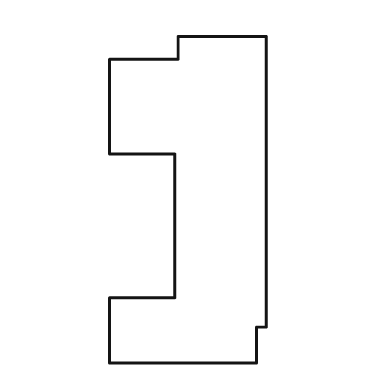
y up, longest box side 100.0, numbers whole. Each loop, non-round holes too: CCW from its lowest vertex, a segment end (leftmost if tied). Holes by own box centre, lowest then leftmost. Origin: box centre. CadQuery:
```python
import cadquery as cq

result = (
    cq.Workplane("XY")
    .moveTo(-24.0, -50.0)
    .lineTo(21.0, -50.0)
    .lineTo(21.0, -39.0)
    .lineTo(24.0, -39.0)
    .lineTo(24.0, 50.0)
    .lineTo(-3.0, 50.0)
    .lineTo(-3.0, 43.0)
    .lineTo(-24.0, 43.0)
    .lineTo(-24.0, 14.0)
    .lineTo(-4.0, 14.0)
    .lineTo(-4.0, -30.0)
    .lineTo(-24.0, -30.0)
    .close()
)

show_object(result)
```